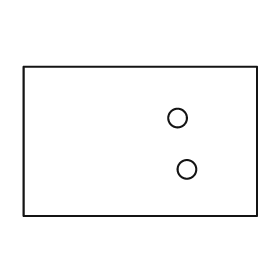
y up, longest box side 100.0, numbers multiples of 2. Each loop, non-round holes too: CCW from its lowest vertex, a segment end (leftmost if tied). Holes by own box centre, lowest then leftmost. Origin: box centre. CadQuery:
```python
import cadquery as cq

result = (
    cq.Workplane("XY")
    .moveTo(-50.0, -32.0)
    .lineTo(50.0, -32.0)
    .lineTo(50.0, 32.0)
    .lineTo(-50.0, 32.0)
    .close()
    .moveTo(20.0, -12.0)
    .circle(4.0)
    .moveTo(16.0, 10.0)
    .circle(4.0)
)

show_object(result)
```